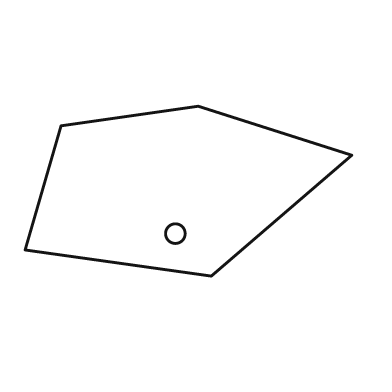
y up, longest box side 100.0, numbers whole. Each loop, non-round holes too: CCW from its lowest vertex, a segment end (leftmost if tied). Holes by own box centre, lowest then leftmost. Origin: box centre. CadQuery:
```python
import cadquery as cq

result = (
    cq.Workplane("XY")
    .moveTo(7.0, -26.0)
    .lineTo(50.0, 11.0)
    .lineTo(3.0, 26.0)
    .lineTo(-39.0, 20.0)
    .lineTo(-50.0, -18.0)
    .close()
    .moveTo(-4.0, -13.0)
    .circle(3.0)
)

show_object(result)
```